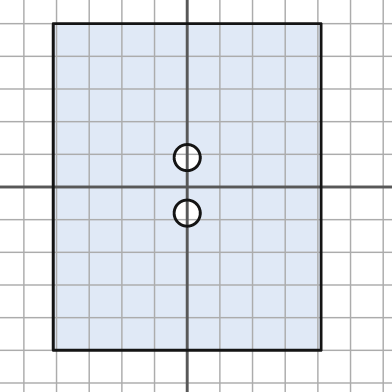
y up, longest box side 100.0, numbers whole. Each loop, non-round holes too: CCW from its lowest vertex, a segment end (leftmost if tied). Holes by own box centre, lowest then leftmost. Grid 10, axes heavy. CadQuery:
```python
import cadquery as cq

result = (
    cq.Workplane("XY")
    .moveTo(-41.0, -50.0)
    .lineTo(41.0, -50.0)
    .lineTo(41.0, 50.0)
    .lineTo(-41.0, 50.0)
    .close()
    .moveTo(0.0, -8.0)
    .circle(4.0)
    .moveTo(0.0, 9.0)
    .circle(4.0)
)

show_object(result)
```